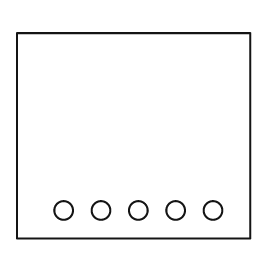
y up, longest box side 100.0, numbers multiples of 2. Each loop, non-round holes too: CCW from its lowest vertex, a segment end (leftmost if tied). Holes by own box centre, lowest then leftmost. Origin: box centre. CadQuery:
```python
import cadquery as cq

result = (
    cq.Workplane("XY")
    .moveTo(-50.0, -44.0)
    .lineTo(50.0, -44.0)
    .lineTo(50.0, 44.0)
    .lineTo(-50.0, 44.0)
    .close()
    .moveTo(-30.0, -32.0)
    .circle(4.0)
    .moveTo(-14.0, -32.0)
    .circle(4.0)
    .moveTo(2.0, -32.0)
    .circle(4.0)
    .moveTo(18.0, -32.0)
    .circle(4.0)
    .moveTo(34.0, -32.0)
    .circle(4.0)
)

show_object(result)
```